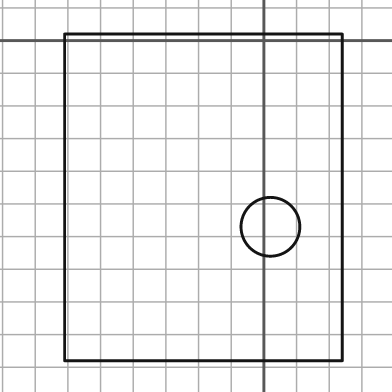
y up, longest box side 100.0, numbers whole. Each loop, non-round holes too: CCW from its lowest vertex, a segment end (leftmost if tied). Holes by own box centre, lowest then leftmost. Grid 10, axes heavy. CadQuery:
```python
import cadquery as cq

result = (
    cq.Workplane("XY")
    .moveTo(-61.0, -98.0)
    .lineTo(24.0, -98.0)
    .lineTo(24.0, 2.0)
    .lineTo(-61.0, 2.0)
    .close()
    .moveTo(2.0, -57.0)
    .circle(9.0)
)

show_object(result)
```